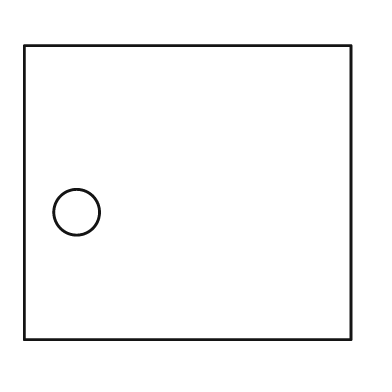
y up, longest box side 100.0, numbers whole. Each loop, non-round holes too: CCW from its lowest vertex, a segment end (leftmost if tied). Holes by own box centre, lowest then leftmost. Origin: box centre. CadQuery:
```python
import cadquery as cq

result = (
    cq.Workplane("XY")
    .moveTo(-50.0, -45.0)
    .lineTo(50.0, -45.0)
    .lineTo(50.0, 45.0)
    .lineTo(-50.0, 45.0)
    .close()
    .moveTo(-34.0, -6.0)
    .circle(7.0)
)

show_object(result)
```